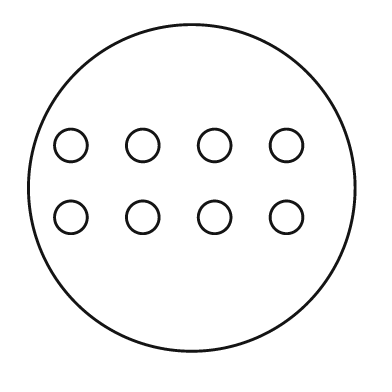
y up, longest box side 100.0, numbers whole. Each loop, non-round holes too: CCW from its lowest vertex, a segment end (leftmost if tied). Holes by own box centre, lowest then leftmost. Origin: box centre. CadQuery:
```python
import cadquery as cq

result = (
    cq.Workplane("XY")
    .moveTo(0.0, 0.0)
    .circle(50.0)
    .moveTo(-37.0, -9.0)
    .circle(5.0)
    .moveTo(-15.0, -9.0)
    .circle(5.0)
    .moveTo(7.0, -9.0)
    .circle(5.0)
    .moveTo(29.0, -9.0)
    .circle(5.0)
    .moveTo(-37.0, 13.0)
    .circle(5.0)
    .moveTo(-15.0, 13.0)
    .circle(5.0)
    .moveTo(7.0, 13.0)
    .circle(5.0)
    .moveTo(29.0, 13.0)
    .circle(5.0)
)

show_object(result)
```